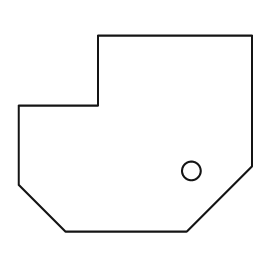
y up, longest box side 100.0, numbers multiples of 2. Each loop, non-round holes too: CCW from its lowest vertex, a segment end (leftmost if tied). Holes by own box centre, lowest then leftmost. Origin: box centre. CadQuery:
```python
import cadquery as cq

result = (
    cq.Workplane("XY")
    .moveTo(-30.0, -42.0)
    .lineTo(22.0, -42.0)
    .lineTo(50.0, -14.0)
    .lineTo(50.0, 42.0)
    .lineTo(-16.0, 42.0)
    .lineTo(-16.0, 12.0)
    .lineTo(-50.0, 12.0)
    .lineTo(-50.0, -22.0)
    .close()
    .moveTo(24.0, -16.0)
    .circle(4.0)
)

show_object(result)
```